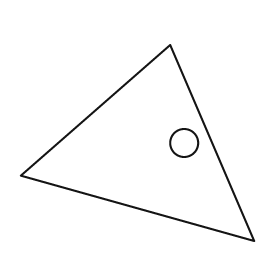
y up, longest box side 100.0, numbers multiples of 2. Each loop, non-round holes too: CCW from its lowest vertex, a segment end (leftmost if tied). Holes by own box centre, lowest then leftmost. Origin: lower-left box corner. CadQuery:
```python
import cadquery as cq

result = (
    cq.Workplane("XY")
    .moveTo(100.0, 0.0)
    .lineTo(64.0, 84.0)
    .lineTo(0.0, 28.0)
    .close()
    .moveTo(70.0, 42.0)
    .circle(6.0)
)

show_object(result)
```